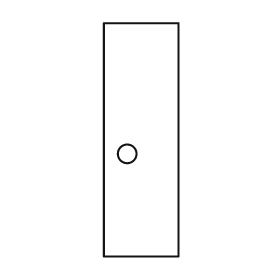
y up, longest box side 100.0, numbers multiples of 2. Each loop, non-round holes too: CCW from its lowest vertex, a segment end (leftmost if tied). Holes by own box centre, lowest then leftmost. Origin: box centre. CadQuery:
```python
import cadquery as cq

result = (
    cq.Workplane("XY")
    .moveTo(-16.0, -50.0)
    .lineTo(16.0, -50.0)
    .lineTo(16.0, 50.0)
    .lineTo(-16.0, 50.0)
    .close()
    .moveTo(-6.0, -6.0)
    .circle(4.0)
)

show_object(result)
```